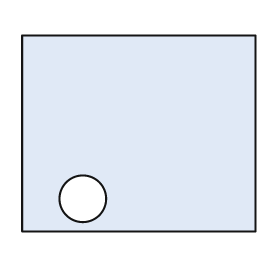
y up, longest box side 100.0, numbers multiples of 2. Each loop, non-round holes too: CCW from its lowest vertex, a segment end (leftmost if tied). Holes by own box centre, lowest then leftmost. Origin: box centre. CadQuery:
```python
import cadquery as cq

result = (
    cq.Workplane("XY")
    .moveTo(-50.0, -42.0)
    .lineTo(50.0, -42.0)
    .lineTo(50.0, 42.0)
    .lineTo(-50.0, 42.0)
    .close()
    .moveTo(-24.0, -28.0)
    .circle(10.0)
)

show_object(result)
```